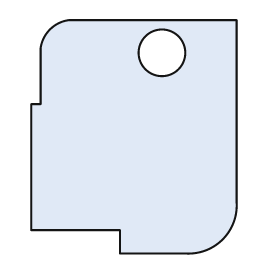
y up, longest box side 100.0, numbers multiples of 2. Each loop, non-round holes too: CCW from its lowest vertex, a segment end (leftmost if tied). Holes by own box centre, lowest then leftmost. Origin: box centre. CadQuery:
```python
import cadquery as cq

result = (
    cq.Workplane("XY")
    .moveTo(-6.0, -50.0)
    .lineTo(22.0, -50.0)
    .threePointArc((38.0, -44.0), (44.0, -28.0))
    .lineTo(44.0, 50.0)
    .lineTo(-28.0, 50.0)
    .threePointArc((-36.0, 46.0), (-40.0, 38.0))
    .lineTo(-40.0, 14.0)
    .lineTo(-44.0, 14.0)
    .lineTo(-44.0, -40.0)
    .lineTo(-6.0, -40.0)
    .close()
    .moveTo(12.0, 36.0)
    .circle(10.0)
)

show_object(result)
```